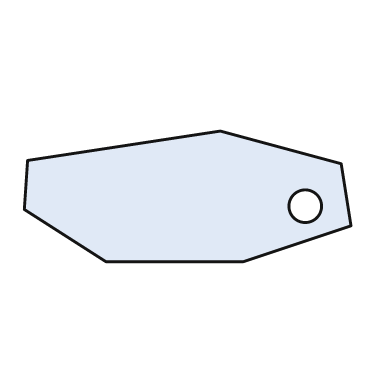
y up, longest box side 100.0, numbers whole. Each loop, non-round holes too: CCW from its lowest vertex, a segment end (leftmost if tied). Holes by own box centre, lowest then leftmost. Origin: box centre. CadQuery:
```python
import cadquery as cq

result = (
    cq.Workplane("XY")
    .moveTo(-25.0, -20.0)
    .lineTo(17.0, -20.0)
    .lineTo(50.0, -9.0)
    .lineTo(47.0, 10.0)
    .lineTo(10.0, 20.0)
    .lineTo(-49.0, 11.0)
    .lineTo(-50.0, -4.0)
    .close()
    .moveTo(36.0, -3.0)
    .circle(5.0)
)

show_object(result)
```